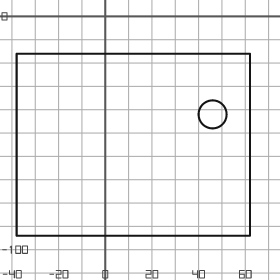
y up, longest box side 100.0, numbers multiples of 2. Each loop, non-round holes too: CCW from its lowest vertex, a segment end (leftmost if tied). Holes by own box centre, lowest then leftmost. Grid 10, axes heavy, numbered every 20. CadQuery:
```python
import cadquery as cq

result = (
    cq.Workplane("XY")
    .moveTo(-38.0, -94.0)
    .lineTo(62.0, -94.0)
    .lineTo(62.0, -16.0)
    .lineTo(-38.0, -16.0)
    .close()
    .moveTo(46.0, -42.0)
    .circle(6.0)
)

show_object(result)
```